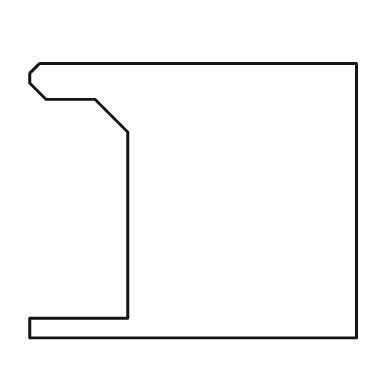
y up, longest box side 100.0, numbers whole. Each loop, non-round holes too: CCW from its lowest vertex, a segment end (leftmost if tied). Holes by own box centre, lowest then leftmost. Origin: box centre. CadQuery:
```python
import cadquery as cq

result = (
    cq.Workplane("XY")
    .moveTo(-50.0, -42.0)
    .lineTo(50.0, -42.0)
    .lineTo(50.0, 42.0)
    .lineTo(-47.0, 42.0)
    .lineTo(-50.0, 39.0)
    .lineTo(-50.0, 36.0)
    .lineTo(-45.0, 31.0)
    .lineTo(-30.0, 31.0)
    .lineTo(-20.0, 21.0)
    .lineTo(-20.0, -36.0)
    .lineTo(-50.0, -36.0)
    .close()
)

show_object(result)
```